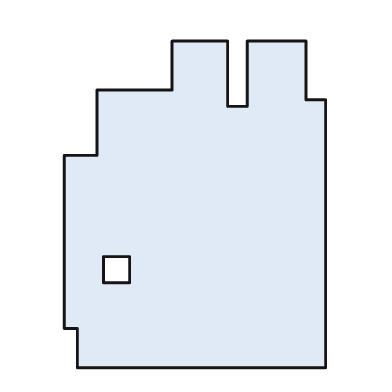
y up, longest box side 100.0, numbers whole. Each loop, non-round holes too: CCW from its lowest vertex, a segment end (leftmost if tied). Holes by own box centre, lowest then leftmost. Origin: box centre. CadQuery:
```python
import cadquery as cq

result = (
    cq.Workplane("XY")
    .moveTo(-36.0, -50.0)
    .lineTo(40.0, -50.0)
    .lineTo(40.0, 32.0)
    .lineTo(34.0, 32.0)
    .lineTo(34.0, 50.0)
    .lineTo(16.0, 50.0)
    .lineTo(16.0, 30.0)
    .lineTo(10.0, 30.0)
    .lineTo(10.0, 50.0)
    .lineTo(-7.0, 50.0)
    .lineTo(-7.0, 35.0)
    .lineTo(-30.0, 35.0)
    .lineTo(-30.0, 15.0)
    .lineTo(-40.0, 15.0)
    .lineTo(-40.0, -38.0)
    .lineTo(-36.0, -38.0)
    .close()
    .moveTo(-28.0, -24.0)
    .lineTo(-20.0, -24.0)
    .lineTo(-20.0, -16.0)
    .lineTo(-28.0, -16.0)
    .close()
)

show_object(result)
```